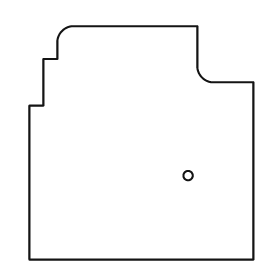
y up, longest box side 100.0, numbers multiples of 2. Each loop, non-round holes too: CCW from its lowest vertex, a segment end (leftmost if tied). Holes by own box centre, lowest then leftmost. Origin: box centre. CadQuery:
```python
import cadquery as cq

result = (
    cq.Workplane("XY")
    .moveTo(-48.0, -50.0)
    .lineTo(48.0, -50.0)
    .lineTo(48.0, 26.0)
    .lineTo(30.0, 26.0)
    .threePointArc((26.0, 28.0), (24.0, 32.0))
    .lineTo(24.0, 50.0)
    .lineTo(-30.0, 50.0)
    .threePointArc((-34.0, 48.0), (-36.0, 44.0))
    .lineTo(-36.0, 36.0)
    .lineTo(-42.0, 36.0)
    .lineTo(-42.0, 16.0)
    .lineTo(-48.0, 16.0)
    .close()
    .moveTo(20.0, -14.0)
    .circle(2.0)
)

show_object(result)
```